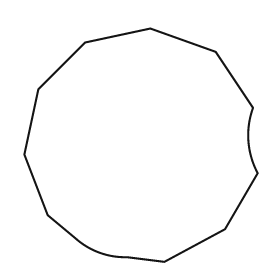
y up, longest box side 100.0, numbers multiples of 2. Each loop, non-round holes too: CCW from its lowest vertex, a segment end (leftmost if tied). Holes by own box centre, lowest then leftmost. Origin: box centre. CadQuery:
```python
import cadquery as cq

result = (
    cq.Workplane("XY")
    .moveTo(10.0, -50.0)
    .lineTo(36.0, -36.0)
    .lineTo(50.0, -12.0)
    .threePointArc((46.0, 2.0), (48.0, 16.0))
    .lineTo(32.0, 40.0)
    .lineTo(4.0, 50.0)
    .lineTo(-24.0, 44.0)
    .lineTo(-44.0, 24.0)
    .lineTo(-50.0, -4.0)
    .lineTo(-40.0, -30.0)
    .lineTo(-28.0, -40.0)
    .threePointArc((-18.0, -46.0), (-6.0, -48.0))
    .close()
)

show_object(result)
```